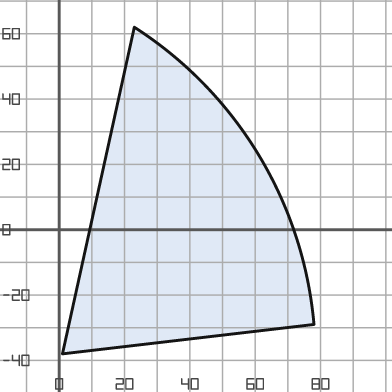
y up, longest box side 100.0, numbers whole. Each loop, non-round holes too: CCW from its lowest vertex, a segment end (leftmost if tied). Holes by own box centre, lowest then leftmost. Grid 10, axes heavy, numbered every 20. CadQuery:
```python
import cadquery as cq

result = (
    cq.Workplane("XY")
    .moveTo(1.0, -38.0)
    .lineTo(78.0, -29.0)
    .threePointArc((61.0, 23.0), (23.0, 62.0))
    .close()
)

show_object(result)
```